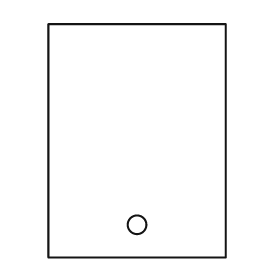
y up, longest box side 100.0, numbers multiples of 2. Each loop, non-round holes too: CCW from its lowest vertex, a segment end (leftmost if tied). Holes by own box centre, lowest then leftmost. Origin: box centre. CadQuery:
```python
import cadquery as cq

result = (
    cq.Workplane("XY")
    .moveTo(-38.0, -50.0)
    .lineTo(38.0, -50.0)
    .lineTo(38.0, 50.0)
    .lineTo(-38.0, 50.0)
    .close()
    .moveTo(0.0, -36.0)
    .circle(4.0)
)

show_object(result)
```